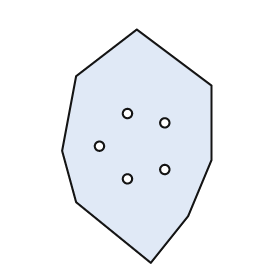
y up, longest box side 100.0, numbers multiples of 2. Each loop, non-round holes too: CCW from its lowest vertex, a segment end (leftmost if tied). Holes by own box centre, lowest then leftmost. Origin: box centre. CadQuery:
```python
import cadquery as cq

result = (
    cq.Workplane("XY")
    .moveTo(6.0, -50.0)
    .lineTo(22.0, -30.0)
    .lineTo(32.0, -6.0)
    .lineTo(32.0, 26.0)
    .lineTo(0.0, 50.0)
    .lineTo(-26.0, 30.0)
    .lineTo(-32.0, -2.0)
    .lineTo(-26.0, -24.0)
    .close()
    .moveTo(-4.0, -14.0)
    .circle(2.0)
    .moveTo(12.0, -10.0)
    .circle(2.0)
    .moveTo(-16.0, 0.0)
    .circle(2.0)
    .moveTo(12.0, 10.0)
    .circle(2.0)
    .moveTo(-4.0, 14.0)
    .circle(2.0)
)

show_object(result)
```